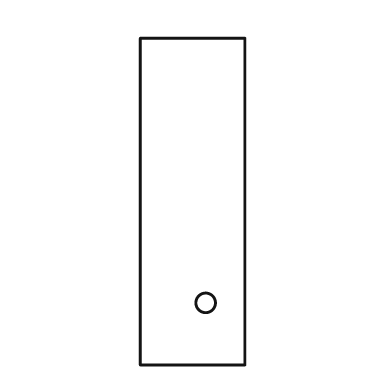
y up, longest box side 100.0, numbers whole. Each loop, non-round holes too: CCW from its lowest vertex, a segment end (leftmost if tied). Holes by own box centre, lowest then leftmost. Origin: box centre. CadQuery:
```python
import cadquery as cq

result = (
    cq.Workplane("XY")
    .moveTo(-16.0, -50.0)
    .lineTo(16.0, -50.0)
    .lineTo(16.0, 50.0)
    .lineTo(-16.0, 50.0)
    .close()
    .moveTo(4.0, -31.0)
    .circle(3.0)
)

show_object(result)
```